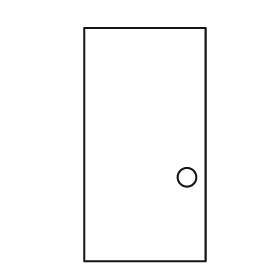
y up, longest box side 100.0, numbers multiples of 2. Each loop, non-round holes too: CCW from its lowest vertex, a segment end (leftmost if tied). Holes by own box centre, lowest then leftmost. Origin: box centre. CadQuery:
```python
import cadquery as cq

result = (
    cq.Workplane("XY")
    .moveTo(-26.0, -50.0)
    .lineTo(26.0, -50.0)
    .lineTo(26.0, 50.0)
    .lineTo(-26.0, 50.0)
    .close()
    .moveTo(18.0, -14.0)
    .circle(4.0)
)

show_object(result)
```